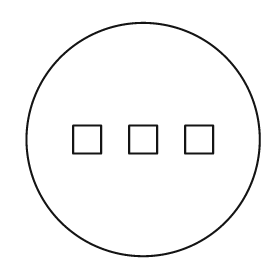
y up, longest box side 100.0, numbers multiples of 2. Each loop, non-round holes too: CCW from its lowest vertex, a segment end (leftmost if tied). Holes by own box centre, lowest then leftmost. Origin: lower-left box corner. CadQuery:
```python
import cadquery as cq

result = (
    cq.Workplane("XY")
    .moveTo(50.0, 50.0)
    .circle(50.0)
    .moveTo(20.0, 44.0)
    .lineTo(32.0, 44.0)
    .lineTo(32.0, 56.0)
    .lineTo(20.0, 56.0)
    .close()
    .moveTo(44.0, 44.0)
    .lineTo(56.0, 44.0)
    .lineTo(56.0, 56.0)
    .lineTo(44.0, 56.0)
    .close()
    .moveTo(68.0, 44.0)
    .lineTo(80.0, 44.0)
    .lineTo(80.0, 56.0)
    .lineTo(68.0, 56.0)
    .close()
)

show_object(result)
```